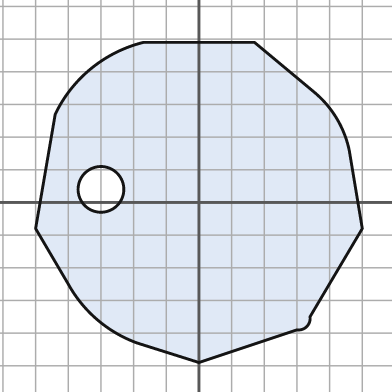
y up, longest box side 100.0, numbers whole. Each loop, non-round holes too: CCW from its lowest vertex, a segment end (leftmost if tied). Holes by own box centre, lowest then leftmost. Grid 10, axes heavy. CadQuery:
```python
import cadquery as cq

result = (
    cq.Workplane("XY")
    .moveTo(0.0, -49.0)
    .lineTo(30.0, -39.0)
    .threePointArc((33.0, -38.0), (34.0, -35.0))
    .lineTo(50.0, -8.0)
    .lineTo(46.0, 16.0)
    .threePointArc((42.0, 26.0), (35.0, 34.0))
    .lineTo(17.0, 49.0)
    .lineTo(-17.0, 49.0)
    .threePointArc((-33.0, 41.0), (-44.0, 27.0))
    .lineTo(-50.0, -8.0)
    .lineTo(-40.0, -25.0)
    .threePointArc((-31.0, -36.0), (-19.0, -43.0))
    .close()
    .moveTo(-30.0, 4.0)
    .circle(7.0)
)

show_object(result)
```